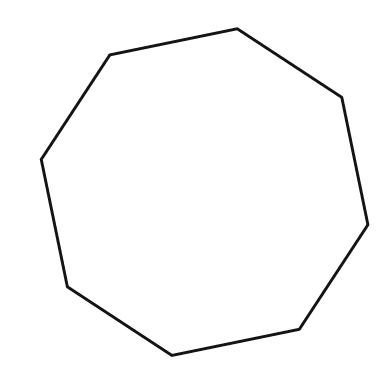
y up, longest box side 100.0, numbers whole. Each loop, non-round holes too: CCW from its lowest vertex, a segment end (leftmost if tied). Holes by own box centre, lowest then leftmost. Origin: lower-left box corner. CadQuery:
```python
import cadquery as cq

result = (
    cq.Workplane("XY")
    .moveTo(40.0, 0.0)
    .lineTo(79.0, 8.0)
    .lineTo(100.0, 40.0)
    .lineTo(92.0, 79.0)
    .lineTo(60.0, 100.0)
    .lineTo(21.0, 92.0)
    .lineTo(0.0, 60.0)
    .lineTo(8.0, 21.0)
    .close()
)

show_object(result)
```